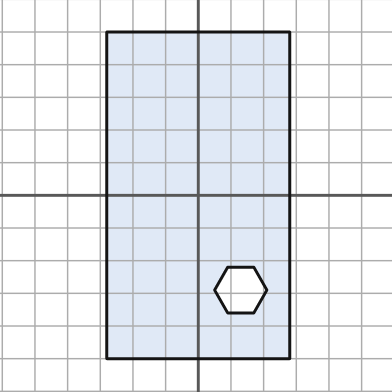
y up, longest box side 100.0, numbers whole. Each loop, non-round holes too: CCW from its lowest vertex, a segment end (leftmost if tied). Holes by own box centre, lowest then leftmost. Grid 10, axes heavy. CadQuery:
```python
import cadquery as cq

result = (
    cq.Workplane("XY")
    .moveTo(-28.0, -50.0)
    .lineTo(28.0, -50.0)
    .lineTo(28.0, 50.0)
    .lineTo(-28.0, 50.0)
    .close()
    .moveTo(9.0, -36.0)
    .lineTo(17.0, -36.0)
    .lineTo(21.0, -29.0)
    .lineTo(17.0, -22.0)
    .lineTo(9.0, -22.0)
    .lineTo(5.0, -29.0)
    .close()
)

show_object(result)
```